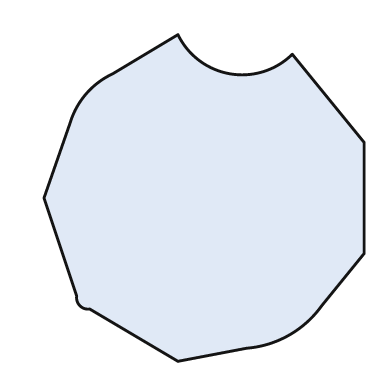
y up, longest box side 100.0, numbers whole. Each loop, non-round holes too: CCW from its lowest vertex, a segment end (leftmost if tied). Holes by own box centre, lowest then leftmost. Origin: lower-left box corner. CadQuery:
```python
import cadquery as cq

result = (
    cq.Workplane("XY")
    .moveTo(41.0, 0.0)
    .lineTo(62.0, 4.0)
    .threePointArc((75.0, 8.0), (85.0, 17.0))
    .lineTo(98.0, 33.0)
    .lineTo(98.0, 67.0)
    .lineTo(76.0, 94.0)
    .threePointArc((57.0, 88.0), (41.0, 100.0))
    .lineTo(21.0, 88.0)
    .threePointArc((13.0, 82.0), (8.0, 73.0))
    .lineTo(0.0, 50.0)
    .lineTo(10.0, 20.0)
    .threePointArc((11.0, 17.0), (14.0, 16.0))
    .close()
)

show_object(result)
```